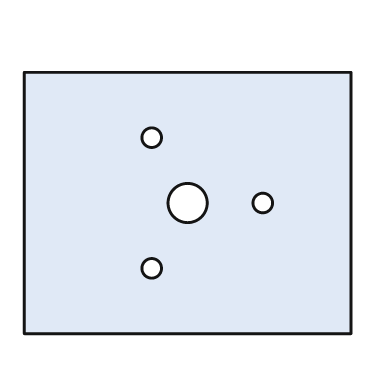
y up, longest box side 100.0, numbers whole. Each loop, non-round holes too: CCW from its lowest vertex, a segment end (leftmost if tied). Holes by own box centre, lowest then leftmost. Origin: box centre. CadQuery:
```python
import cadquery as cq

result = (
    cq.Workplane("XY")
    .moveTo(-50.0, -40.0)
    .lineTo(50.0, -40.0)
    .lineTo(50.0, 40.0)
    .lineTo(-50.0, 40.0)
    .close()
    .moveTo(-11.0, -20.0)
    .circle(3.0)
    .moveTo(0.0, 0.0)
    .circle(6.0)
    .moveTo(23.0, 0.0)
    .circle(3.0)
    .moveTo(-11.0, 20.0)
    .circle(3.0)
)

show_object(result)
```